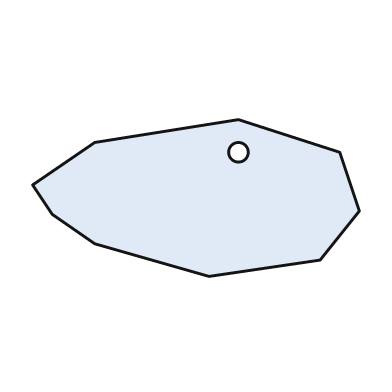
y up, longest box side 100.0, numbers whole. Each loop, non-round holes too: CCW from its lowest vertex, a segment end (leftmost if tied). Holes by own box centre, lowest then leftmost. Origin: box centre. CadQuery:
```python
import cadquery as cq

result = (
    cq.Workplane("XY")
    .moveTo(4.0, -24.0)
    .lineTo(38.0, -19.0)
    .lineTo(50.0, -4.0)
    .lineTo(44.0, 14.0)
    .lineTo(13.0, 24.0)
    .lineTo(-31.0, 17.0)
    .lineTo(-50.0, 4.0)
    .lineTo(-44.0, -5.0)
    .lineTo(-31.0, -14.0)
    .close()
    .moveTo(13.0, 14.0)
    .circle(3.0)
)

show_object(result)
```